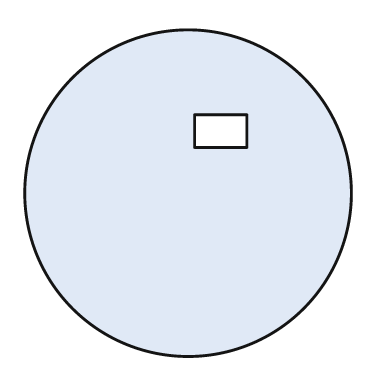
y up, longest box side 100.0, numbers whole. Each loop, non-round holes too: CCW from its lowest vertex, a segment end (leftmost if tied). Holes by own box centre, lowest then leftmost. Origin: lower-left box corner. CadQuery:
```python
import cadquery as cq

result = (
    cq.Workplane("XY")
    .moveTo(50.0, 50.0)
    .circle(50.0)
    .moveTo(52.0, 64.0)
    .lineTo(68.0, 64.0)
    .lineTo(68.0, 74.0)
    .lineTo(52.0, 74.0)
    .close()
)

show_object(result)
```